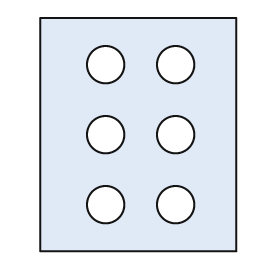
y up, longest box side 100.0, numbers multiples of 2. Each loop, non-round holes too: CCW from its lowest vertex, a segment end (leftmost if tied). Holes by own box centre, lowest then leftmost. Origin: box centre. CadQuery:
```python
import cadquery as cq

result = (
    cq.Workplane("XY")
    .moveTo(-42.0, -50.0)
    .lineTo(42.0, -50.0)
    .lineTo(42.0, 50.0)
    .lineTo(-42.0, 50.0)
    .close()
    .moveTo(-14.0, -30.0)
    .circle(8.0)
    .moveTo(16.0, -30.0)
    .circle(8.0)
    .moveTo(-14.0, 0.0)
    .circle(8.0)
    .moveTo(16.0, 0.0)
    .circle(8.0)
    .moveTo(-14.0, 30.0)
    .circle(8.0)
    .moveTo(16.0, 30.0)
    .circle(8.0)
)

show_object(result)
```